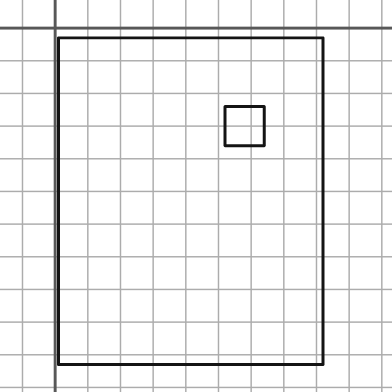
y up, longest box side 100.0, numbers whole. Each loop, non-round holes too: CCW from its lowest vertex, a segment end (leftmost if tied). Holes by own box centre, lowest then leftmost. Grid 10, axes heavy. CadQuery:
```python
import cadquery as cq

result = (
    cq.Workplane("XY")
    .moveTo(1.0, -103.0)
    .lineTo(82.0, -103.0)
    .lineTo(82.0, -3.0)
    .lineTo(1.0, -3.0)
    .close()
    .moveTo(52.0, -36.0)
    .lineTo(64.0, -36.0)
    .lineTo(64.0, -24.0)
    .lineTo(52.0, -24.0)
    .close()
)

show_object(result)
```